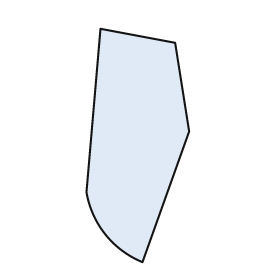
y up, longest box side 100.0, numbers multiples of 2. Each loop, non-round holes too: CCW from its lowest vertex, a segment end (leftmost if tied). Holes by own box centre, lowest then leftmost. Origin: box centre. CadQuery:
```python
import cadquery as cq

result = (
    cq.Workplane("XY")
    .moveTo(2.0, -50.0)
    .lineTo(22.0, 6.0)
    .lineTo(16.0, 44.0)
    .lineTo(-16.0, 50.0)
    .lineTo(-22.0, -20.0)
    .threePointArc((-14.0, -38.0), (2.0, -50.0))
    .close()
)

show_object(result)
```